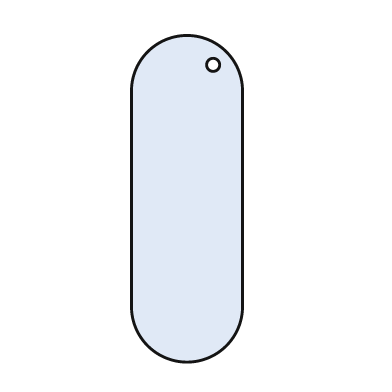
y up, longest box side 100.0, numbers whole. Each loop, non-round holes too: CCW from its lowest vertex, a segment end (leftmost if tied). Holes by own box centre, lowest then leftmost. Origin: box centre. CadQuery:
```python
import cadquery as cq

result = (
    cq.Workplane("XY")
    .moveTo(-17.0, -33.0)
    .threePointArc((0.0, -50.0), (17.0, -33.0))
    .lineTo(17.0, 33.0)
    .threePointArc((0.0, 50.0), (-17.0, 33.0))
    .close()
    .moveTo(8.0, 41.0)
    .circle(2.0)
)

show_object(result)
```